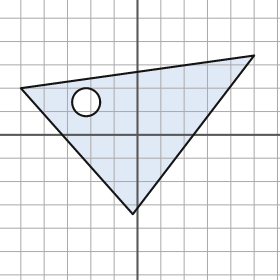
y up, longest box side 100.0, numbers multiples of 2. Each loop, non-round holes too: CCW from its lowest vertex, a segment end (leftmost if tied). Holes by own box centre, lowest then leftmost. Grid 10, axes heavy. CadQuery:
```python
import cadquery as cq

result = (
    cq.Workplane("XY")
    .moveTo(-2.0, -34.0)
    .lineTo(50.0, 34.0)
    .lineTo(-50.0, 20.0)
    .close()
    .moveTo(-22.0, 14.0)
    .circle(6.0)
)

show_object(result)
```